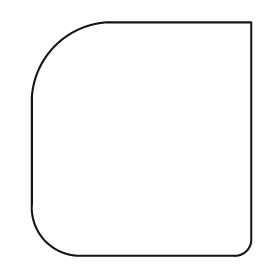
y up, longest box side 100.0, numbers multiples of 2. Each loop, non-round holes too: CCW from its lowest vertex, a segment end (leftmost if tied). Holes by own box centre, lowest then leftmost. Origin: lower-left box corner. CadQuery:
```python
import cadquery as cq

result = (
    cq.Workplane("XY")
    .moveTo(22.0, 0.0)
    .lineTo(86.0, 0.0)
    .threePointArc((92.0, 2.0), (94.0, 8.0))
    .lineTo(94.0, 100.0)
    .lineTo(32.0, 100.0)
    .threePointArc((10.0, 90.0), (0.0, 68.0))
    .lineTo(0.0, 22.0)
    .threePointArc((6.0, 6.0), (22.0, 0.0))
    .close()
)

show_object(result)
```